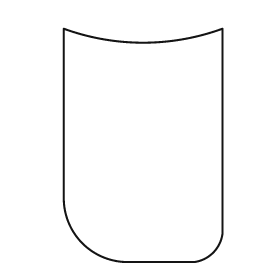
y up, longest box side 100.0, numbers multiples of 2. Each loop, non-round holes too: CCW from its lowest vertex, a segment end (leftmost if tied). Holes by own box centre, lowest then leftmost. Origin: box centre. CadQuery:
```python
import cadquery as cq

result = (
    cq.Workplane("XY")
    .moveTo(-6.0, -50.0)
    .lineTo(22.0, -50.0)
    .threePointArc((30.0, -46.0), (34.0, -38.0))
    .lineTo(34.0, 50.0)
    .threePointArc((0.0, 44.0), (-34.0, 50.0))
    .lineTo(-34.0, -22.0)
    .threePointArc((-26.0, -42.0), (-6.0, -50.0))
    .close()
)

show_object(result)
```